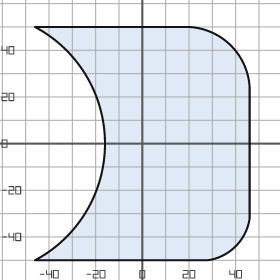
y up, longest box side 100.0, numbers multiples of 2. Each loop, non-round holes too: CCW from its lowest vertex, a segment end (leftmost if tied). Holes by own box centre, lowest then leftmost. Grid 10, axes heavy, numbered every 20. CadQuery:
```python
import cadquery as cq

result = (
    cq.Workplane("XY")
    .moveTo(-46.0, -50.0)
    .lineTo(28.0, -50.0)
    .threePointArc((40.0, -44.0), (46.0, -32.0))
    .lineTo(46.0, 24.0)
    .threePointArc((38.0, 42.0), (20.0, 50.0))
    .lineTo(-46.0, 50.0)
    .threePointArc((-16.0, 0.0), (-46.0, -50.0))
    .close()
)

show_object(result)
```